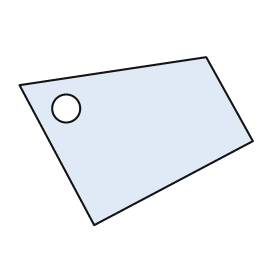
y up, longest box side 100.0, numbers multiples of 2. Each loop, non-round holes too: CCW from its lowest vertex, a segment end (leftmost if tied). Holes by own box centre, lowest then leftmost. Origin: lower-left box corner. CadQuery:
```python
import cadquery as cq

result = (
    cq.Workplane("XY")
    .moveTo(32.0, 0.0)
    .lineTo(100.0, 36.0)
    .lineTo(80.0, 72.0)
    .lineTo(0.0, 60.0)
    .close()
    .moveTo(20.0, 50.0)
    .circle(6.0)
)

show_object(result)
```